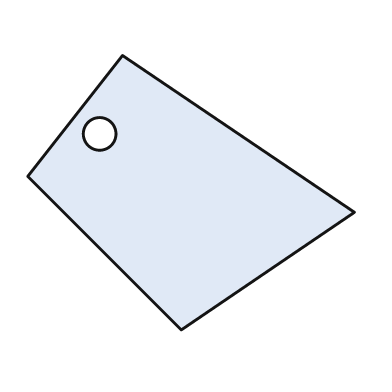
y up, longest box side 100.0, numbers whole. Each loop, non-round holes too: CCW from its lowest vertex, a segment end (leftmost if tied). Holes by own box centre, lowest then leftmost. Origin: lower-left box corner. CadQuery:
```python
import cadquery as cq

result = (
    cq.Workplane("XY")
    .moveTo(47.0, 0.0)
    .lineTo(100.0, 36.0)
    .lineTo(29.0, 84.0)
    .lineTo(0.0, 47.0)
    .close()
    .moveTo(22.0, 60.0)
    .circle(5.0)
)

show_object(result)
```